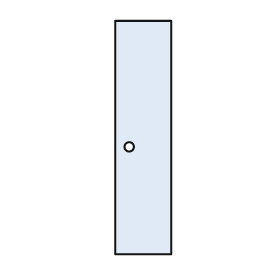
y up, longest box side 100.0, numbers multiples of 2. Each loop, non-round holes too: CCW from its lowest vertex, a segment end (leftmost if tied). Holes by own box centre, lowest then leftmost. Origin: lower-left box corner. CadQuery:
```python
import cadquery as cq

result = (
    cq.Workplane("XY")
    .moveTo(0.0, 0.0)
    .lineTo(24.0, 0.0)
    .lineTo(24.0, 100.0)
    .lineTo(0.0, 100.0)
    .close()
    .moveTo(6.0, 46.0)
    .circle(2.0)
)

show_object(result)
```